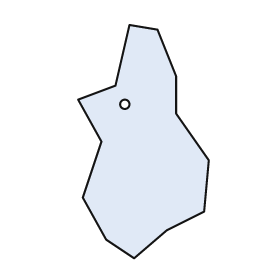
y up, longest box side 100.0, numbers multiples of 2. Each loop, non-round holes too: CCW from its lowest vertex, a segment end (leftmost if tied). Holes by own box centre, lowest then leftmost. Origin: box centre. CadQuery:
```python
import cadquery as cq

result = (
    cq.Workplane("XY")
    .moveTo(-4.0, -50.0)
    .lineTo(10.0, -38.0)
    .lineTo(26.0, -30.0)
    .lineTo(28.0, -8.0)
    .lineTo(14.0, 12.0)
    .lineTo(14.0, 28.0)
    .lineTo(6.0, 48.0)
    .lineTo(-6.0, 50.0)
    .lineTo(-12.0, 24.0)
    .lineTo(-28.0, 18.0)
    .lineTo(-18.0, 0.0)
    .lineTo(-26.0, -24.0)
    .lineTo(-16.0, -42.0)
    .close()
    .moveTo(-8.0, 16.0)
    .circle(2.0)
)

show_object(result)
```